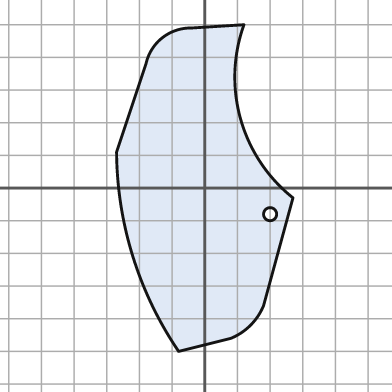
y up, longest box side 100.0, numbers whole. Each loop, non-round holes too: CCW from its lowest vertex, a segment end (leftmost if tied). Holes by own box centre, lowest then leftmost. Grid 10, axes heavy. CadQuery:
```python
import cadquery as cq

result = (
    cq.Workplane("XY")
    .moveTo(-8.0, -50.0)
    .lineTo(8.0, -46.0)
    .threePointArc((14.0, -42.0), (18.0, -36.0))
    .lineTo(27.0, -3.0)
    .threePointArc((11.0, 21.0), (12.0, 50.0))
    .lineTo(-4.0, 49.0)
    .threePointArc((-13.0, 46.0), (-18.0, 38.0))
    .lineTo(-27.0, 11.0)
    .threePointArc((-22.0, -21.0), (-8.0, -50.0))
    .close()
    .moveTo(20.0, -8.0)
    .circle(2.0)
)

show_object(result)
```